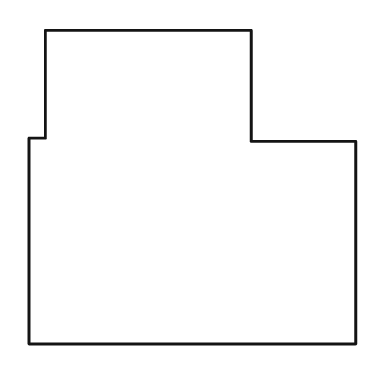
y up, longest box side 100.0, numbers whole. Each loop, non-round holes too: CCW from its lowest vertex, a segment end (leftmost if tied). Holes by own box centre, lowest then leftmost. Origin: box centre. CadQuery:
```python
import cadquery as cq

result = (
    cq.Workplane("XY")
    .moveTo(-50.0, -48.0)
    .lineTo(50.0, -48.0)
    .lineTo(50.0, 14.0)
    .lineTo(18.0, 14.0)
    .lineTo(18.0, 48.0)
    .lineTo(-45.0, 48.0)
    .lineTo(-45.0, 15.0)
    .lineTo(-50.0, 15.0)
    .close()
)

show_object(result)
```